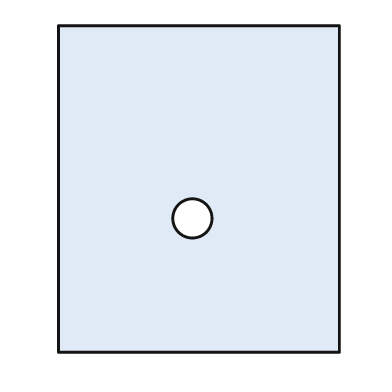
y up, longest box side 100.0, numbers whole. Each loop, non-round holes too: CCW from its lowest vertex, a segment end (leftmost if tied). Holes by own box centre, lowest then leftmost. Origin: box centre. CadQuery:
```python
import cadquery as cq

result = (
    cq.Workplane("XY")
    .moveTo(-43.0, -50.0)
    .lineTo(43.0, -50.0)
    .lineTo(43.0, 50.0)
    .lineTo(-43.0, 50.0)
    .close()
    .moveTo(-2.0, -9.0)
    .circle(6.0)
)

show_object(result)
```